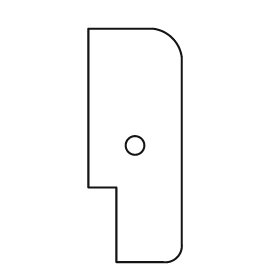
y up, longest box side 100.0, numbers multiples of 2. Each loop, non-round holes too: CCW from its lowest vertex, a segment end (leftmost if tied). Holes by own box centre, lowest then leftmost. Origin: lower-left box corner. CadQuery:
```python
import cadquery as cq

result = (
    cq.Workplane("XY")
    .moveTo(12.0, 0.0)
    .lineTo(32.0, 0.0)
    .threePointArc((38.0, 2.0), (40.0, 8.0))
    .lineTo(40.0, 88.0)
    .threePointArc((36.0, 96.0), (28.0, 100.0))
    .lineTo(0.0, 100.0)
    .lineTo(0.0, 32.0)
    .lineTo(12.0, 32.0)
    .close()
    .moveTo(20.0, 50.0)
    .circle(4.0)
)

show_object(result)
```